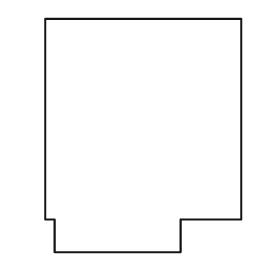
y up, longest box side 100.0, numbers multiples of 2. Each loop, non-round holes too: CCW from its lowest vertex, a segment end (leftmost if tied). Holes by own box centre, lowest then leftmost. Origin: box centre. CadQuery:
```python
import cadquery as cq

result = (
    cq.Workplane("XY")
    .moveTo(-38.0, -50.0)
    .lineTo(16.0, -50.0)
    .lineTo(16.0, -36.0)
    .lineTo(42.0, -36.0)
    .lineTo(42.0, 50.0)
    .lineTo(-42.0, 50.0)
    .lineTo(-42.0, -36.0)
    .lineTo(-38.0, -36.0)
    .close()
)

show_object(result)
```